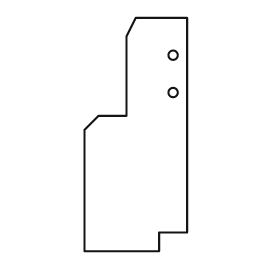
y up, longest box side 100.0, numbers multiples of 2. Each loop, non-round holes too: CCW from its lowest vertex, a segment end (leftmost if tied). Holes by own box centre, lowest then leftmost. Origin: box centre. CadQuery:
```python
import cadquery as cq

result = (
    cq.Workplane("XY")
    .moveTo(-22.0, -50.0)
    .lineTo(10.0, -50.0)
    .lineTo(10.0, -42.0)
    .lineTo(22.0, -42.0)
    .lineTo(22.0, 50.0)
    .lineTo(0.0, 50.0)
    .lineTo(-4.0, 42.0)
    .lineTo(-4.0, 8.0)
    .lineTo(-16.0, 8.0)
    .lineTo(-22.0, 2.0)
    .close()
    .moveTo(16.0, 18.0)
    .circle(2.0)
    .moveTo(16.0, 34.0)
    .circle(2.0)
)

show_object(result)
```